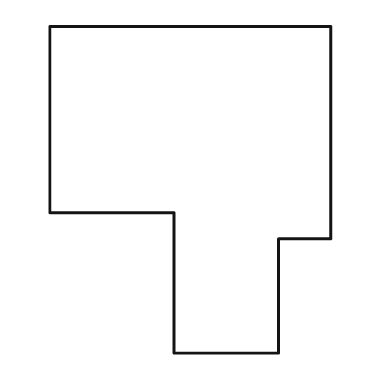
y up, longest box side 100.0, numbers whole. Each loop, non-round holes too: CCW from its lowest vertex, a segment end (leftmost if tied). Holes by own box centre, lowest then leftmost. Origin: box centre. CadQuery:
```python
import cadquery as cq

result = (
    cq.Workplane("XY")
    .moveTo(-5.0, -50.0)
    .lineTo(27.0, -50.0)
    .lineTo(27.0, -15.0)
    .lineTo(43.0, -15.0)
    .lineTo(43.0, 50.0)
    .lineTo(-43.0, 50.0)
    .lineTo(-43.0, -7.0)
    .lineTo(-5.0, -7.0)
    .close()
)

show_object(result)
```